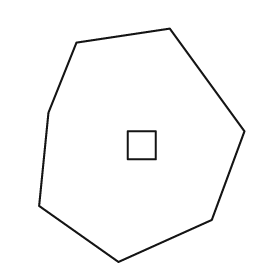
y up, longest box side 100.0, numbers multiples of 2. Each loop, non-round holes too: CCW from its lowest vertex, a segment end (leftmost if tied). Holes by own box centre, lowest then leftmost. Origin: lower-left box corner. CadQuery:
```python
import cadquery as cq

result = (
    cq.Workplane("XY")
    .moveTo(34.0, 0.0)
    .lineTo(74.0, 18.0)
    .lineTo(88.0, 56.0)
    .lineTo(56.0, 100.0)
    .lineTo(16.0, 94.0)
    .lineTo(4.0, 64.0)
    .lineTo(0.0, 24.0)
    .close()
    .moveTo(38.0, 44.0)
    .lineTo(50.0, 44.0)
    .lineTo(50.0, 56.0)
    .lineTo(38.0, 56.0)
    .close()
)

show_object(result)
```